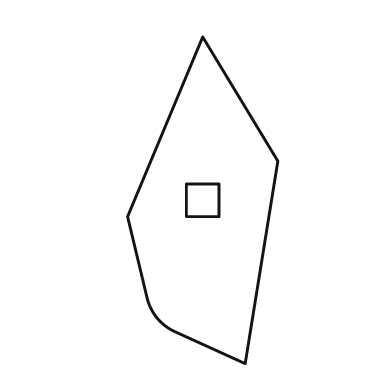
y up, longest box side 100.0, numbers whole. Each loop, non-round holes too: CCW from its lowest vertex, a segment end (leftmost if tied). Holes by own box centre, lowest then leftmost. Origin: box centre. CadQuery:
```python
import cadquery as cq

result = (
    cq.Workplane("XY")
    .moveTo(13.0, -50.0)
    .lineTo(23.0, 12.0)
    .lineTo(0.0, 50.0)
    .lineTo(-23.0, -5.0)
    .lineTo(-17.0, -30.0)
    .threePointArc((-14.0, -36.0), (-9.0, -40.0))
    .close()
    .moveTo(-5.0, -5.0)
    .lineTo(5.0, -5.0)
    .lineTo(5.0, 5.0)
    .lineTo(-5.0, 5.0)
    .close()
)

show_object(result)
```